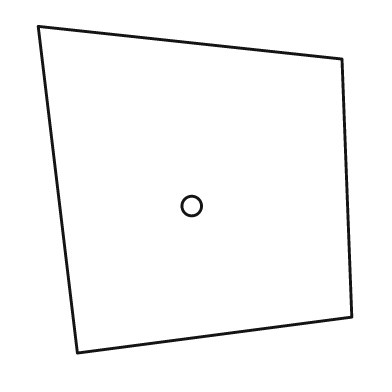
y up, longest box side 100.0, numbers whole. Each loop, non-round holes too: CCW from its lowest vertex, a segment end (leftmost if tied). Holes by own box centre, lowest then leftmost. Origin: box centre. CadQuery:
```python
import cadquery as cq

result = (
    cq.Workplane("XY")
    .moveTo(-36.0, -50.0)
    .lineTo(48.0, -39.0)
    .lineTo(45.0, 40.0)
    .lineTo(-48.0, 50.0)
    .close()
    .moveTo(-1.0, -5.0)
    .circle(3.0)
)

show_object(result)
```